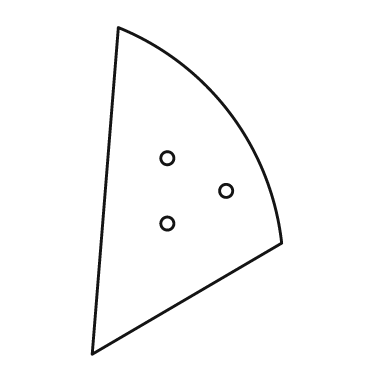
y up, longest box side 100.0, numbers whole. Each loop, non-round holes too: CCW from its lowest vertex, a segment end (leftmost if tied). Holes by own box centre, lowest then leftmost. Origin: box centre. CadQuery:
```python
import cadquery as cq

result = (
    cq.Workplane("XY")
    .moveTo(-29.0, -50.0)
    .lineTo(29.0, -16.0)
    .threePointArc((13.0, 24.0), (-21.0, 50.0))
    .close()
    .moveTo(-6.0, -10.0)
    .circle(2.0)
    .moveTo(12.0, 0.0)
    .circle(2.0)
    .moveTo(-6.0, 10.0)
    .circle(2.0)
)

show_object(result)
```